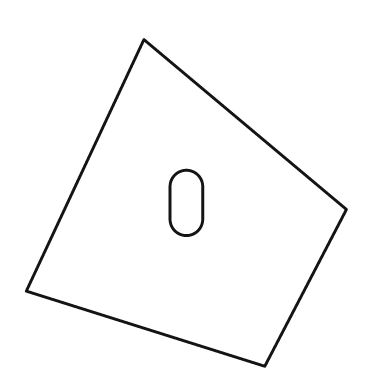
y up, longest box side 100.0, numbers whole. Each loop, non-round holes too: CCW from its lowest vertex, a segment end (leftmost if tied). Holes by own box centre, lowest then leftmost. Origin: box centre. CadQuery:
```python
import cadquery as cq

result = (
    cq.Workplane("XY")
    .moveTo(24.0, -50.0)
    .lineTo(49.0, -2.0)
    .lineTo(-13.0, 50.0)
    .lineTo(-49.0, -27.0)
    .close()
    .moveTo(-5.0, -5.0)
    .threePointArc((0.0, -10.0), (5.0, -5.0))
    .lineTo(5.0, 5.0)
    .threePointArc((0.0, 10.0), (-5.0, 5.0))
    .close()
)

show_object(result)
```